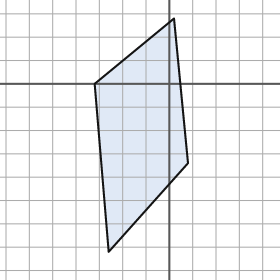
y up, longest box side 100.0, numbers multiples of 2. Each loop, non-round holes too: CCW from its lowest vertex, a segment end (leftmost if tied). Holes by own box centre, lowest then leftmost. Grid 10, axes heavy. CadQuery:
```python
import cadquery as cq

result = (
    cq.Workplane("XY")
    .moveTo(-26.0, -72.0)
    .lineTo(8.0, -34.0)
    .lineTo(2.0, 28.0)
    .lineTo(-32.0, 0.0)
    .close()
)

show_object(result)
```